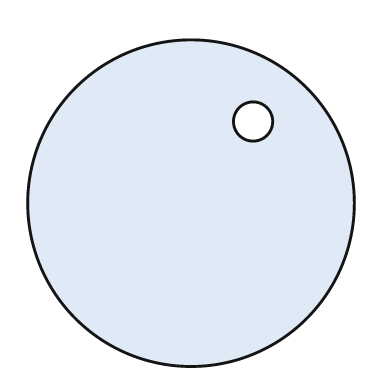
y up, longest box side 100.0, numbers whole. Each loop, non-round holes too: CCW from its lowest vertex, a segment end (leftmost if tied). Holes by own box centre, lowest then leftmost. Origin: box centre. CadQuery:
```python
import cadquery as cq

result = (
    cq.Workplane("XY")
    .moveTo(0.0, 0.0)
    .circle(50.0)
    .moveTo(19.0, 25.0)
    .circle(6.0)
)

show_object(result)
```